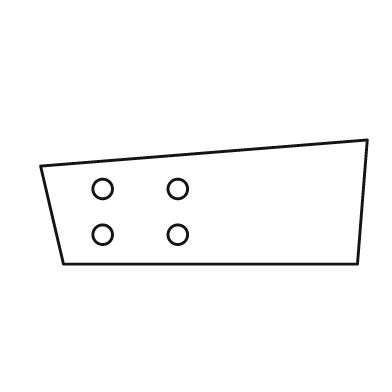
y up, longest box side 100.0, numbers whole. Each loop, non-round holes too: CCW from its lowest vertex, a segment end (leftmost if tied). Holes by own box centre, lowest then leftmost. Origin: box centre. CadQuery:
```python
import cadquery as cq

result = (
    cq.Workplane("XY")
    .moveTo(-43.0, -19.0)
    .lineTo(47.0, -19.0)
    .lineTo(50.0, 19.0)
    .lineTo(-50.0, 11.0)
    .close()
    .moveTo(-31.0, -10.0)
    .circle(3.0)
    .moveTo(-8.0, -10.0)
    .circle(3.0)
    .moveTo(-31.0, 4.0)
    .circle(3.0)
    .moveTo(-8.0, 4.0)
    .circle(3.0)
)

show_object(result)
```